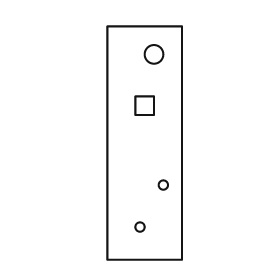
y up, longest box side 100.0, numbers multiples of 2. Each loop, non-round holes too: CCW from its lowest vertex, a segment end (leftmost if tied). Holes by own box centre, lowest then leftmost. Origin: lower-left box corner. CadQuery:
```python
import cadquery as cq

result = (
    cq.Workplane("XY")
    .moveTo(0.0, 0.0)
    .lineTo(32.0, 0.0)
    .lineTo(32.0, 100.0)
    .lineTo(0.0, 100.0)
    .close()
    .moveTo(14.0, 14.0)
    .circle(2.0)
    .moveTo(24.0, 32.0)
    .circle(2.0)
    .moveTo(12.0, 62.0)
    .lineTo(20.0, 62.0)
    .lineTo(20.0, 70.0)
    .lineTo(12.0, 70.0)
    .close()
    .moveTo(20.0, 88.0)
    .circle(4.0)
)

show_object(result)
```